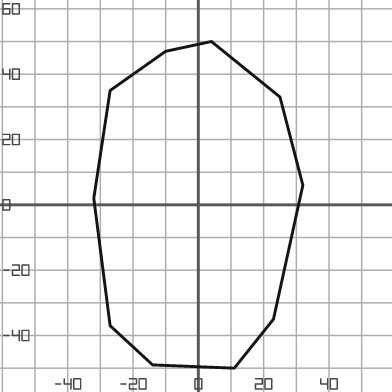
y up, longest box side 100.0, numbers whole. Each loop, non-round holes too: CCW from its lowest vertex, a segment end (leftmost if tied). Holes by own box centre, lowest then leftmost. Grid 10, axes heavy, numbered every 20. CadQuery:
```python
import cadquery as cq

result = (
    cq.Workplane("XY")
    .moveTo(11.0, -50.0)
    .lineTo(23.0, -35.0)
    .lineTo(32.0, 6.0)
    .lineTo(25.0, 33.0)
    .lineTo(4.0, 50.0)
    .lineTo(-10.0, 47.0)
    .lineTo(-27.0, 35.0)
    .lineTo(-32.0, 2.0)
    .lineTo(-27.0, -37.0)
    .lineTo(-14.0, -49.0)
    .close()
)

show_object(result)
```